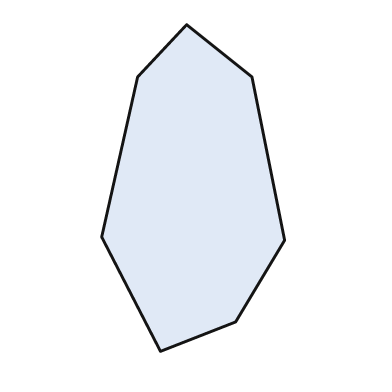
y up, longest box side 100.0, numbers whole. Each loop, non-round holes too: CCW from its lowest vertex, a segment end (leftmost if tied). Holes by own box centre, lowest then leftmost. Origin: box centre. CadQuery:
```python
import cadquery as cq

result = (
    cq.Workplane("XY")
    .moveTo(-10.0, -50.0)
    .lineTo(13.0, -41.0)
    .lineTo(28.0, -16.0)
    .lineTo(18.0, 34.0)
    .lineTo(-2.0, 50.0)
    .lineTo(-17.0, 34.0)
    .lineTo(-28.0, -15.0)
    .close()
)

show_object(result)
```